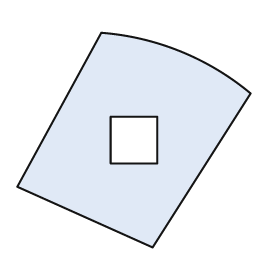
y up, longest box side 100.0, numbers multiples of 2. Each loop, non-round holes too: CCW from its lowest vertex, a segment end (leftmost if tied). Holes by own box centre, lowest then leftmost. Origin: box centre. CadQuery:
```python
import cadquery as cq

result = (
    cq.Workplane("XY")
    .moveTo(8.0, -46.0)
    .lineTo(50.0, 20.0)
    .threePointArc((20.0, 38.0), (-14.0, 46.0))
    .lineTo(-50.0, -20.0)
    .close()
    .moveTo(-10.0, -10.0)
    .lineTo(10.0, -10.0)
    .lineTo(10.0, 10.0)
    .lineTo(-10.0, 10.0)
    .close()
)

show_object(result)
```